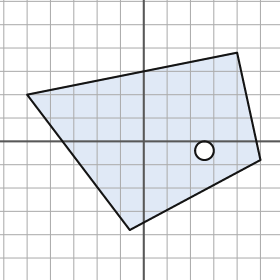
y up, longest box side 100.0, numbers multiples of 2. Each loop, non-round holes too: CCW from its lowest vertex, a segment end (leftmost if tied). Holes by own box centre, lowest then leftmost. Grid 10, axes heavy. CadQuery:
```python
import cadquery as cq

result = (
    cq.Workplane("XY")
    .moveTo(-6.0, -38.0)
    .lineTo(50.0, -8.0)
    .lineTo(40.0, 38.0)
    .lineTo(-50.0, 20.0)
    .close()
    .moveTo(26.0, -4.0)
    .circle(4.0)
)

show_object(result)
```